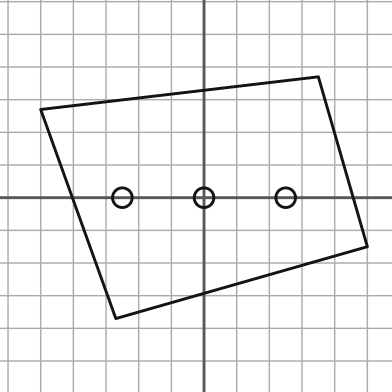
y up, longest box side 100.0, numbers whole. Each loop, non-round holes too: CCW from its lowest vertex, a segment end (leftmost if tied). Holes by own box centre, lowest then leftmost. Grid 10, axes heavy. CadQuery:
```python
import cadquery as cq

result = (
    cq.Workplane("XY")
    .moveTo(-27.0, -37.0)
    .lineTo(50.0, -15.0)
    .lineTo(35.0, 37.0)
    .lineTo(-50.0, 27.0)
    .close()
    .moveTo(-25.0, 0.0)
    .circle(3.0)
    .moveTo(0.0, 0.0)
    .circle(3.0)
    .moveTo(25.0, 0.0)
    .circle(3.0)
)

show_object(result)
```